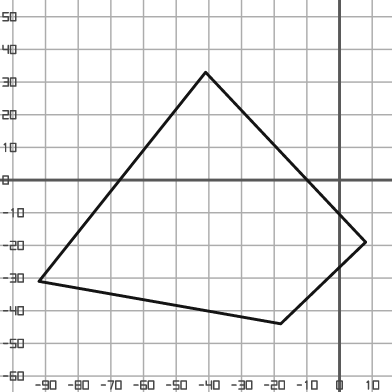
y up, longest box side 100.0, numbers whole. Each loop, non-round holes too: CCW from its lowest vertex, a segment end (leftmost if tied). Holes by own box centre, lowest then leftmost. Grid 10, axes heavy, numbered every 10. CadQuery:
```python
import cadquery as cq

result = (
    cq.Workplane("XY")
    .moveTo(-18.0, -44.0)
    .lineTo(8.0, -19.0)
    .lineTo(-41.0, 33.0)
    .lineTo(-92.0, -31.0)
    .close()
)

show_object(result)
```